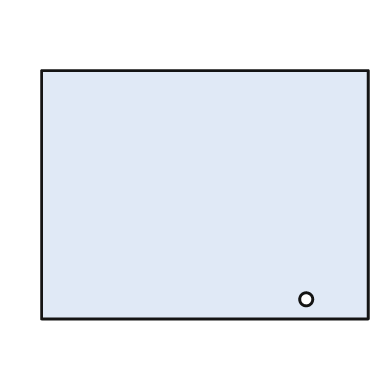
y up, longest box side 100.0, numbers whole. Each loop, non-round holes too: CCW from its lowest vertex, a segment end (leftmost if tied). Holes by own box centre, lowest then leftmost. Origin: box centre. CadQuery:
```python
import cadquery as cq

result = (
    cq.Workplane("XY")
    .moveTo(-50.0, -38.0)
    .lineTo(50.0, -38.0)
    .lineTo(50.0, 38.0)
    .lineTo(-50.0, 38.0)
    .close()
    .moveTo(31.0, -32.0)
    .circle(2.0)
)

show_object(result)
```